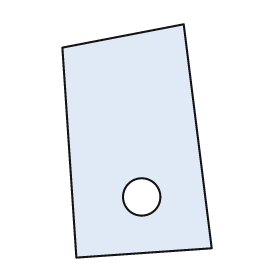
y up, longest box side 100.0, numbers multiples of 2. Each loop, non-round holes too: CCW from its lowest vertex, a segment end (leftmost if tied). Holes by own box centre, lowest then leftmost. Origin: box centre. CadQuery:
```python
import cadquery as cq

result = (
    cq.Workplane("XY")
    .moveTo(-26.0, -50.0)
    .lineTo(32.0, -46.0)
    .lineTo(20.0, 50.0)
    .lineTo(-32.0, 40.0)
    .close()
    .moveTo(2.0, -24.0)
    .circle(8.0)
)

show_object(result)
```